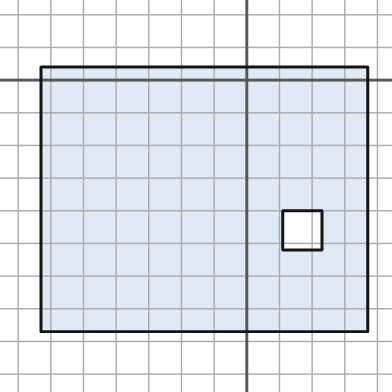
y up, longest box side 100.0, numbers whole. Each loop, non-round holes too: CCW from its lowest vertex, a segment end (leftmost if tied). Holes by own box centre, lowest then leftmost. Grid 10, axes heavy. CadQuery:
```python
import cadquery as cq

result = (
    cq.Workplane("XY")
    .moveTo(-63.0, -77.0)
    .lineTo(37.0, -77.0)
    .lineTo(37.0, 4.0)
    .lineTo(-63.0, 4.0)
    .close()
    .moveTo(11.0, -52.0)
    .lineTo(23.0, -52.0)
    .lineTo(23.0, -40.0)
    .lineTo(11.0, -40.0)
    .close()
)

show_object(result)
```